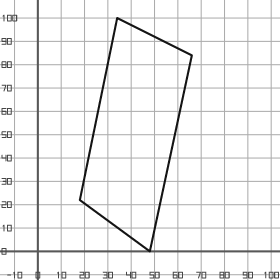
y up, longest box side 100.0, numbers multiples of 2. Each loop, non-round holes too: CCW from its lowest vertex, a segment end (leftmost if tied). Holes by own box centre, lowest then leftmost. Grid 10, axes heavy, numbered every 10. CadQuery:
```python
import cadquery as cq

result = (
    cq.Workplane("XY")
    .moveTo(48.0, 0.0)
    .lineTo(66.0, 84.0)
    .lineTo(34.0, 100.0)
    .lineTo(18.0, 22.0)
    .close()
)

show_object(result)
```